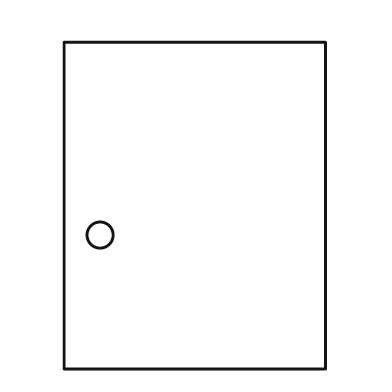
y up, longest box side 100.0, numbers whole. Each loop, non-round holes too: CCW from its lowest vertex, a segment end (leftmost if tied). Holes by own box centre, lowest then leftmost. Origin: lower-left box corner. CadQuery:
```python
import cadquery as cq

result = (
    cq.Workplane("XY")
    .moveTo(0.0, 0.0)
    .lineTo(80.0, 0.0)
    .lineTo(80.0, 100.0)
    .lineTo(0.0, 100.0)
    .close()
    .moveTo(11.0, 41.0)
    .circle(4.0)
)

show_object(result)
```